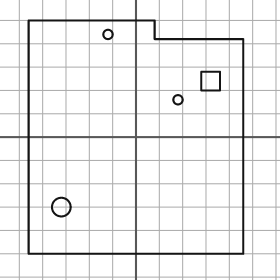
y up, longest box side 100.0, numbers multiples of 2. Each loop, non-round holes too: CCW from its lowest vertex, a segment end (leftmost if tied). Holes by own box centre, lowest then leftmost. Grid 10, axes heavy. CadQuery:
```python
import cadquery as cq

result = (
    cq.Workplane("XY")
    .moveTo(-46.0, -50.0)
    .lineTo(46.0, -50.0)
    .lineTo(46.0, 42.0)
    .lineTo(8.0, 42.0)
    .lineTo(8.0, 50.0)
    .lineTo(-46.0, 50.0)
    .close()
    .moveTo(-32.0, -30.0)
    .circle(4.0)
    .moveTo(18.0, 16.0)
    .circle(2.0)
    .moveTo(28.0, 20.0)
    .lineTo(36.0, 20.0)
    .lineTo(36.0, 28.0)
    .lineTo(28.0, 28.0)
    .close()
    .moveTo(-12.0, 44.0)
    .circle(2.0)
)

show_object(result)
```